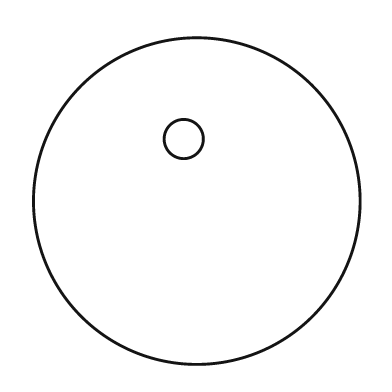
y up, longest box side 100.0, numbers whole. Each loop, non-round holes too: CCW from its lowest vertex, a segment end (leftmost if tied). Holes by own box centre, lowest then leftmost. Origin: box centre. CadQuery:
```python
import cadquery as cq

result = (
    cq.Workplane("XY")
    .moveTo(0.0, 0.0)
    .circle(50.0)
    .moveTo(-4.0, 19.0)
    .circle(6.0)
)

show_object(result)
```